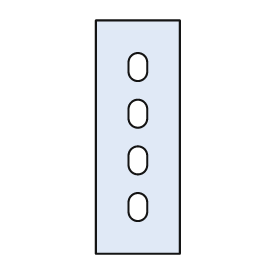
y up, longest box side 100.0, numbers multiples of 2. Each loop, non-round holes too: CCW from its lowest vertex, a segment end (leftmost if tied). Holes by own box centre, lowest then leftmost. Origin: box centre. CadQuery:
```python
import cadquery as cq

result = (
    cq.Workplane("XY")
    .moveTo(-18.0, -50.0)
    .lineTo(18.0, -50.0)
    .lineTo(18.0, 50.0)
    .lineTo(-18.0, 50.0)
    .close()
    .moveTo(-4.0, -32.0)
    .threePointArc((0.0, -36.0), (4.0, -32.0))
    .lineTo(4.0, -28.0)
    .threePointArc((0.0, -24.0), (-4.0, -28.0))
    .close()
    .moveTo(-4.0, -12.0)
    .threePointArc((0.0, -16.0), (4.0, -12.0))
    .lineTo(4.0, -8.0)
    .threePointArc((0.0, -4.0), (-4.0, -8.0))
    .close()
    .moveTo(-4.0, 8.0)
    .threePointArc((0.0, 4.0), (4.0, 8.0))
    .lineTo(4.0, 12.0)
    .threePointArc((0.0, 16.0), (-4.0, 12.0))
    .close()
    .moveTo(-4.0, 28.0)
    .threePointArc((0.0, 24.0), (4.0, 28.0))
    .lineTo(4.0, 32.0)
    .threePointArc((0.0, 36.0), (-4.0, 32.0))
    .close()
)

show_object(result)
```